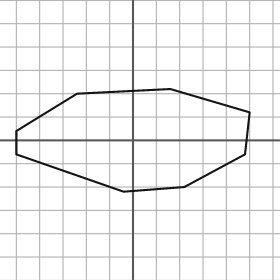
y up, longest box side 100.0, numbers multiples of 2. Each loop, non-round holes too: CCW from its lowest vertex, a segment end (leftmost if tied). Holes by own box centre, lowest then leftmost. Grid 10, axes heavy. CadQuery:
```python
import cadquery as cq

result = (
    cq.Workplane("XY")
    .moveTo(-4.0, -22.0)
    .lineTo(22.0, -20.0)
    .lineTo(48.0, -6.0)
    .lineTo(50.0, 12.0)
    .lineTo(16.0, 22.0)
    .lineTo(-24.0, 20.0)
    .lineTo(-50.0, 4.0)
    .lineTo(-50.0, -6.0)
    .close()
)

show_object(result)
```